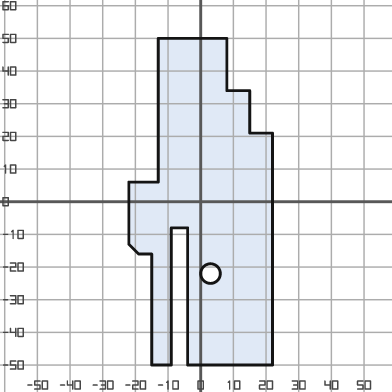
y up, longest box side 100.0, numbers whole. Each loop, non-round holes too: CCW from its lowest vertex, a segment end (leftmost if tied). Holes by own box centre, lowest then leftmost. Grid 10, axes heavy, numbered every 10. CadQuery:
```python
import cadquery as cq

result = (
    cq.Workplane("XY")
    .moveTo(-15.0, -50.0)
    .lineTo(-9.0, -50.0)
    .lineTo(-9.0, -8.0)
    .lineTo(-4.0, -8.0)
    .lineTo(-4.0, -50.0)
    .lineTo(22.0, -50.0)
    .lineTo(22.0, 21.0)
    .lineTo(15.0, 21.0)
    .lineTo(15.0, 34.0)
    .lineTo(8.0, 34.0)
    .lineTo(8.0, 50.0)
    .lineTo(-13.0, 50.0)
    .lineTo(-13.0, 6.0)
    .lineTo(-22.0, 6.0)
    .lineTo(-22.0, -13.0)
    .lineTo(-19.0, -16.0)
    .lineTo(-15.0, -16.0)
    .close()
    .moveTo(3.0, -22.0)
    .circle(3.0)
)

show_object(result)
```